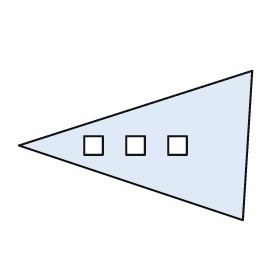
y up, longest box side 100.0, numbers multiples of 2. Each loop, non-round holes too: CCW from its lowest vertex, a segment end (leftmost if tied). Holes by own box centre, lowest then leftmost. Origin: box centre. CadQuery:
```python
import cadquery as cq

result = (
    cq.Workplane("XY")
    .moveTo(46.0, -32.0)
    .lineTo(50.0, 32.0)
    .lineTo(-50.0, 0.0)
    .close()
    .moveTo(-22.0, -4.0)
    .lineTo(-14.0, -4.0)
    .lineTo(-14.0, 4.0)
    .lineTo(-22.0, 4.0)
    .close()
    .moveTo(-4.0, -4.0)
    .lineTo(4.0, -4.0)
    .lineTo(4.0, 4.0)
    .lineTo(-4.0, 4.0)
    .close()
    .moveTo(14.0, -4.0)
    .lineTo(22.0, -4.0)
    .lineTo(22.0, 4.0)
    .lineTo(14.0, 4.0)
    .close()
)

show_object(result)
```